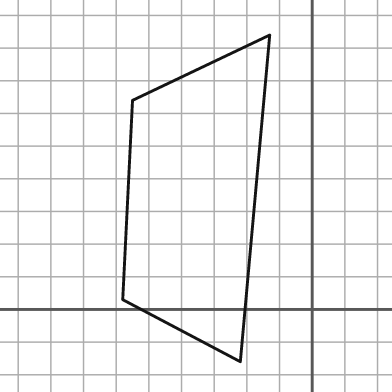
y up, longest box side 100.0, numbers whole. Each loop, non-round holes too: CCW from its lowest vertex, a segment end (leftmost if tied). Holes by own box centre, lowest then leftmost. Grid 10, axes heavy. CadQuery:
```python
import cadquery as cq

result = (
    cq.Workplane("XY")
    .moveTo(-22.0, -16.0)
    .lineTo(-13.0, 84.0)
    .lineTo(-55.0, 64.0)
    .lineTo(-58.0, 3.0)
    .close()
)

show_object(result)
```